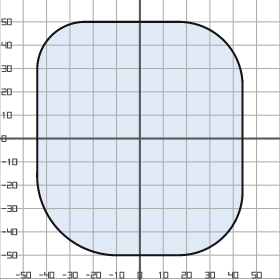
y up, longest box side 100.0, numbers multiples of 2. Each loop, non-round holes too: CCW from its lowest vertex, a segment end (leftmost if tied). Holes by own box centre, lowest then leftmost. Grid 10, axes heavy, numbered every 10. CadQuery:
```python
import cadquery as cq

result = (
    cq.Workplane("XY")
    .moveTo(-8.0, -50.0)
    .lineTo(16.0, -50.0)
    .threePointArc((36.0, -42.0), (44.0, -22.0))
    .lineTo(44.0, 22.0)
    .threePointArc((36.0, 42.0), (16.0, 50.0))
    .lineTo(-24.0, 50.0)
    .threePointArc((-38.0, 44.0), (-44.0, 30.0))
    .lineTo(-44.0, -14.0)
    .threePointArc((-34.0, -40.0), (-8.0, -50.0))
    .close()
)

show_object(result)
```